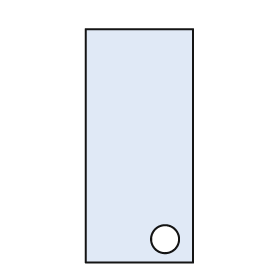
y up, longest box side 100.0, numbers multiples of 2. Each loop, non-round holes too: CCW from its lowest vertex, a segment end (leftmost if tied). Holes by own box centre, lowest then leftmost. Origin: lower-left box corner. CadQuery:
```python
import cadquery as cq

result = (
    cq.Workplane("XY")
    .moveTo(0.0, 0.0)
    .lineTo(46.0, 0.0)
    .lineTo(46.0, 100.0)
    .lineTo(0.0, 100.0)
    .close()
    .moveTo(34.0, 10.0)
    .circle(6.0)
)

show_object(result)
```